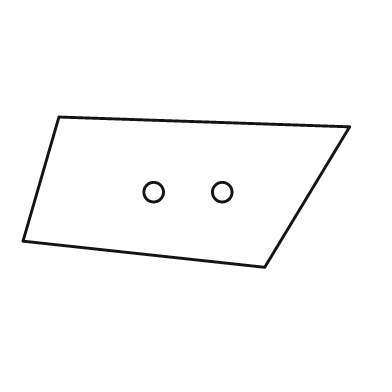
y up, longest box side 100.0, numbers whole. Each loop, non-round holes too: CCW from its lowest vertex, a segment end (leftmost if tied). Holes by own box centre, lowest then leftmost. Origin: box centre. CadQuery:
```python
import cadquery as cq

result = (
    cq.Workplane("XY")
    .moveTo(24.0, -23.0)
    .lineTo(50.0, 20.0)
    .lineTo(-39.0, 23.0)
    .lineTo(-50.0, -15.0)
    .close()
    .moveTo(-10.0, 0.0)
    .circle(3.0)
    .moveTo(11.0, 0.0)
    .circle(3.0)
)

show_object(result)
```